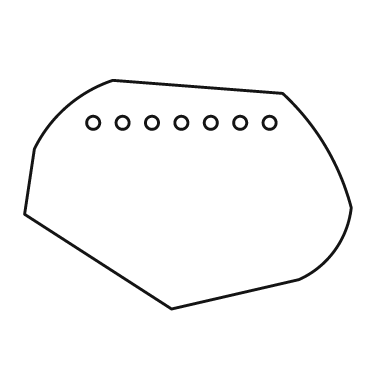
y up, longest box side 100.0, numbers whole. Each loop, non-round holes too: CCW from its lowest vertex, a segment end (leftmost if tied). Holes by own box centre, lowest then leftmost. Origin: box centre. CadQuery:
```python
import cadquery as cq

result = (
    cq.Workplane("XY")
    .moveTo(-5.0, -35.0)
    .lineTo(34.0, -26.0)
    .threePointArc((45.0, -17.0), (50.0, -4.0))
    .threePointArc((42.0, 15.0), (29.0, 31.0))
    .lineTo(-23.0, 35.0)
    .threePointArc((-37.0, 27.0), (-47.0, 14.0))
    .lineTo(-50.0, -6.0)
    .close()
    .moveTo(-29.0, 22.0)
    .circle(2.0)
    .moveTo(-20.0, 22.0)
    .circle(2.0)
    .moveTo(-11.0, 22.0)
    .circle(2.0)
    .moveTo(-2.0, 22.0)
    .circle(2.0)
    .moveTo(7.0, 22.0)
    .circle(2.0)
    .moveTo(16.0, 22.0)
    .circle(2.0)
    .moveTo(25.0, 22.0)
    .circle(2.0)
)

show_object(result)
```